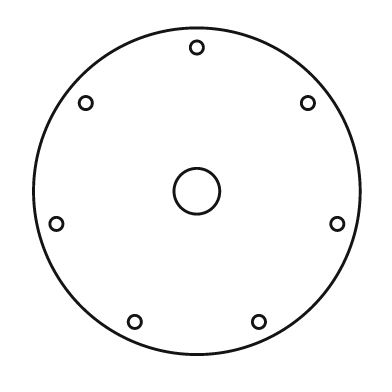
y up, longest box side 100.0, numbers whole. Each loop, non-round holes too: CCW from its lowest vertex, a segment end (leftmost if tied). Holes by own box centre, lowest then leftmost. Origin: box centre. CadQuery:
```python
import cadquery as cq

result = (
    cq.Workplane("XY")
    .moveTo(0.0, 0.0)
    .circle(50.0)
    .moveTo(-19.0, -40.0)
    .circle(2.0)
    .moveTo(19.0, -40.0)
    .circle(2.0)
    .moveTo(-43.0, -10.0)
    .circle(2.0)
    .moveTo(43.0, -10.0)
    .circle(2.0)
    .moveTo(0.0, 0.0)
    .circle(7.0)
    .moveTo(-34.0, 27.0)
    .circle(2.0)
    .moveTo(34.0, 27.0)
    .circle(2.0)
    .moveTo(0.0, 44.0)
    .circle(2.0)
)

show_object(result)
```